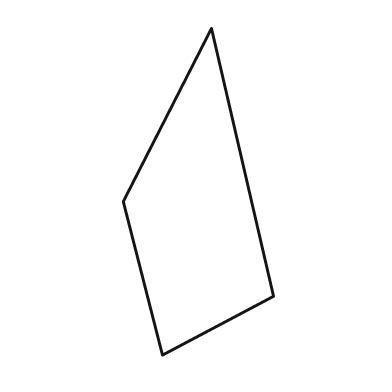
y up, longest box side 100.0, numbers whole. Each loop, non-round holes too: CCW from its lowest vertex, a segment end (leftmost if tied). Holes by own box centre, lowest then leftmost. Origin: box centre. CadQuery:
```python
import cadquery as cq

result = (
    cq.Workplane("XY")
    .moveTo(-11.0, -50.0)
    .lineTo(23.0, -32.0)
    .lineTo(4.0, 50.0)
    .lineTo(-23.0, -3.0)
    .close()
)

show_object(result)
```